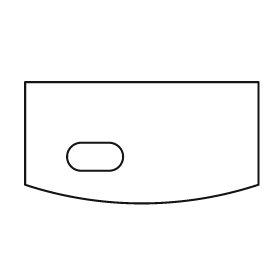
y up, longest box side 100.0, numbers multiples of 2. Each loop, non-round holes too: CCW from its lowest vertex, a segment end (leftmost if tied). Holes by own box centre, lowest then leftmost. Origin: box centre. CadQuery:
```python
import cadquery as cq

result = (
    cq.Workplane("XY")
    .moveTo(-50.0, -18.0)
    .threePointArc((0.0, -26.0), (50.0, -18.0))
    .lineTo(50.0, 26.0)
    .lineTo(-50.0, 26.0)
    .close()
    .moveTo(-26.0, -12.0)
    .lineTo(-14.0, -12.0)
    .threePointArc((-8.0, -6.0), (-14.0, 0.0))
    .lineTo(-26.0, 0.0)
    .threePointArc((-32.0, -6.0), (-26.0, -12.0))
    .close()
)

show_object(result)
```